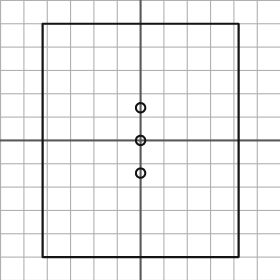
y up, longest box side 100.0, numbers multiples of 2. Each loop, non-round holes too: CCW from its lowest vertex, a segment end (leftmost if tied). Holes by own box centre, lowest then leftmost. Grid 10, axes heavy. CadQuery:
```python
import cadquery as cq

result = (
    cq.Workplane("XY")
    .moveTo(-42.0, -50.0)
    .lineTo(42.0, -50.0)
    .lineTo(42.0, 50.0)
    .lineTo(-42.0, 50.0)
    .close()
    .moveTo(0.0, -14.0)
    .circle(2.0)
    .moveTo(0.0, 0.0)
    .circle(2.0)
    .moveTo(0.0, 14.0)
    .circle(2.0)
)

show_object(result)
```